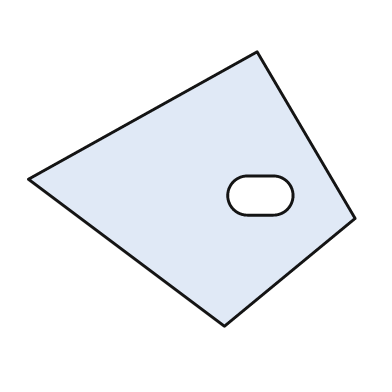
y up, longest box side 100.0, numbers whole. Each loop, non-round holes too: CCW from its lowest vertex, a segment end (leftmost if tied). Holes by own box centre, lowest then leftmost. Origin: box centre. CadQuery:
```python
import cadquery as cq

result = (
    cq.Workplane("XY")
    .moveTo(10.0, -42.0)
    .lineTo(50.0, -9.0)
    .lineTo(20.0, 42.0)
    .lineTo(-50.0, 3.0)
    .close()
    .moveTo(17.0, -8.0)
    .lineTo(25.0, -8.0)
    .threePointArc((31.0, -2.0), (25.0, 4.0))
    .lineTo(17.0, 4.0)
    .threePointArc((11.0, -2.0), (17.0, -8.0))
    .close()
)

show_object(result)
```